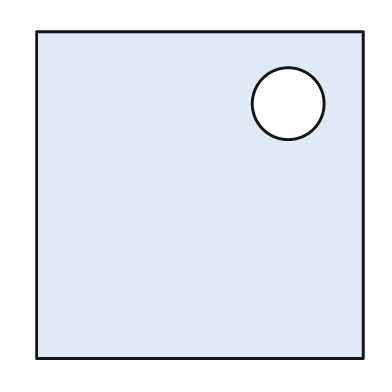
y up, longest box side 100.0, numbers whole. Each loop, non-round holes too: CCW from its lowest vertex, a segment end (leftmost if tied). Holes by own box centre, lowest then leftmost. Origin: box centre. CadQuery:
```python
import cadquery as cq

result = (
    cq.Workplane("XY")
    .moveTo(-50.0, -50.0)
    .lineTo(50.0, -50.0)
    .lineTo(50.0, 50.0)
    .lineTo(-50.0, 50.0)
    .close()
    .moveTo(27.0, 28.0)
    .circle(11.0)
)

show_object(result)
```